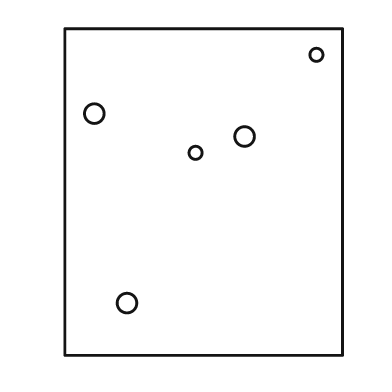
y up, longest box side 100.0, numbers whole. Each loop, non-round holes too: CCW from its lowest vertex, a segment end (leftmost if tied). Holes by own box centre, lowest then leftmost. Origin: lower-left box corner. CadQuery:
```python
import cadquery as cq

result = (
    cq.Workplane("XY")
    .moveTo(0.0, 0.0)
    .lineTo(85.0, 0.0)
    .lineTo(85.0, 100.0)
    .lineTo(0.0, 100.0)
    .close()
    .moveTo(19.0, 16.0)
    .circle(3.0)
    .moveTo(40.0, 62.0)
    .circle(2.0)
    .moveTo(55.0, 67.0)
    .circle(3.0)
    .moveTo(9.0, 74.0)
    .circle(3.0)
    .moveTo(77.0, 92.0)
    .circle(2.0)
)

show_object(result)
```